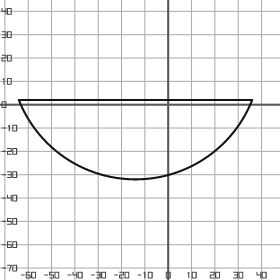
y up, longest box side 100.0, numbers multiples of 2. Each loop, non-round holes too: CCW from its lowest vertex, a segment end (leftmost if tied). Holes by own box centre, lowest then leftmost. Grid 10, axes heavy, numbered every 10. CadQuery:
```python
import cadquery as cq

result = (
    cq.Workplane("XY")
    .moveTo(-64.0, 2.0)
    .threePointArc((-14.0, -32.0), (36.0, 2.0))
    .close()
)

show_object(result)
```